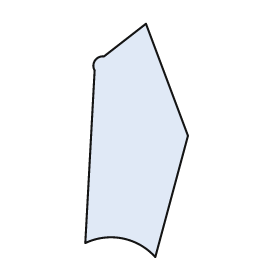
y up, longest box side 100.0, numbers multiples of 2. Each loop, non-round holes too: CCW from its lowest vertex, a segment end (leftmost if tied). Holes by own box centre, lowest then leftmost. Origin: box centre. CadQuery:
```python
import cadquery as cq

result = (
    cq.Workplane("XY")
    .moveTo(8.0, -50.0)
    .lineTo(22.0, 2.0)
    .lineTo(4.0, 50.0)
    .lineTo(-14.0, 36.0)
    .threePointArc((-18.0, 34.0), (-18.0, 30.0))
    .lineTo(-22.0, -44.0)
    .threePointArc((-6.0, -42.0), (8.0, -50.0))
    .close()
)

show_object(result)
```